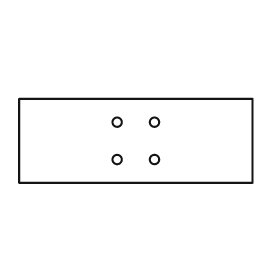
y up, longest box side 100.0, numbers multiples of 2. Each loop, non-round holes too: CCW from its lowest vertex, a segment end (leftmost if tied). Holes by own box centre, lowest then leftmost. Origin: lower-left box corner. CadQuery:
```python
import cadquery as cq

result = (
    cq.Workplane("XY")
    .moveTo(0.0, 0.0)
    .lineTo(100.0, 0.0)
    .lineTo(100.0, 36.0)
    .lineTo(0.0, 36.0)
    .close()
    .moveTo(42.0, 10.0)
    .circle(2.0)
    .moveTo(58.0, 10.0)
    .circle(2.0)
    .moveTo(42.0, 26.0)
    .circle(2.0)
    .moveTo(58.0, 26.0)
    .circle(2.0)
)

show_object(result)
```